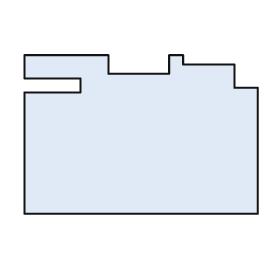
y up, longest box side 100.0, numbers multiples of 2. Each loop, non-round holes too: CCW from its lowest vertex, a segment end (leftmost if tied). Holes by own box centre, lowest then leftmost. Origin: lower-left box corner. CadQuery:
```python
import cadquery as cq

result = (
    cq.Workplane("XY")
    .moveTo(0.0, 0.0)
    .lineTo(100.0, 0.0)
    .lineTo(100.0, 54.0)
    .lineTo(90.0, 54.0)
    .lineTo(90.0, 64.0)
    .lineTo(68.0, 64.0)
    .lineTo(68.0, 68.0)
    .lineTo(62.0, 68.0)
    .lineTo(62.0, 60.0)
    .lineTo(36.0, 60.0)
    .lineTo(36.0, 68.0)
    .lineTo(0.0, 68.0)
    .lineTo(0.0, 58.0)
    .lineTo(24.0, 58.0)
    .lineTo(24.0, 52.0)
    .lineTo(0.0, 52.0)
    .close()
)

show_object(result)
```